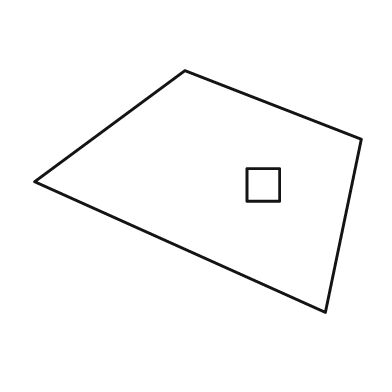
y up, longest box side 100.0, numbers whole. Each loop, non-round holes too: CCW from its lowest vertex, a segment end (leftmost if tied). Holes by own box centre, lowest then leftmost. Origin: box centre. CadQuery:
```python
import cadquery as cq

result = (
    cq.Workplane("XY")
    .moveTo(39.0, -37.0)
    .lineTo(50.0, 16.0)
    .lineTo(-4.0, 37.0)
    .lineTo(-50.0, 3.0)
    .close()
    .moveTo(15.0, -3.0)
    .lineTo(25.0, -3.0)
    .lineTo(25.0, 7.0)
    .lineTo(15.0, 7.0)
    .close()
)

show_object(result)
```